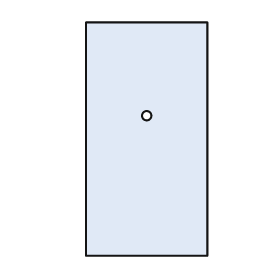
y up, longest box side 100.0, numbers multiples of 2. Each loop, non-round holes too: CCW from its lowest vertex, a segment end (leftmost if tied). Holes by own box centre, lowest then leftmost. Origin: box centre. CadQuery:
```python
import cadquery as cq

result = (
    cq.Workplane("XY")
    .moveTo(-26.0, -50.0)
    .lineTo(26.0, -50.0)
    .lineTo(26.0, 50.0)
    .lineTo(-26.0, 50.0)
    .close()
    .moveTo(0.0, 10.0)
    .circle(2.0)
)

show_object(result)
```